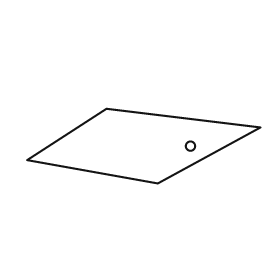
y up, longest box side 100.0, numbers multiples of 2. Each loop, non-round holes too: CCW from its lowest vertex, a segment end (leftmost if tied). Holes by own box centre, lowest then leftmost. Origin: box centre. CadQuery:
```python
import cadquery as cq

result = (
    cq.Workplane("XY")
    .moveTo(6.0, -16.0)
    .lineTo(50.0, 8.0)
    .lineTo(-16.0, 16.0)
    .lineTo(-50.0, -6.0)
    .close()
    .moveTo(20.0, 0.0)
    .circle(2.0)
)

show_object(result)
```